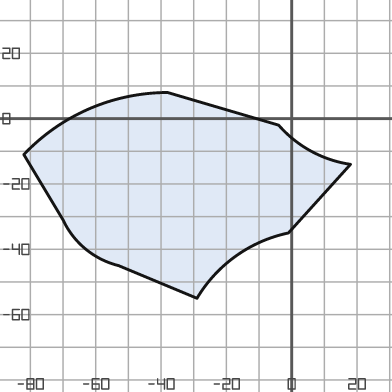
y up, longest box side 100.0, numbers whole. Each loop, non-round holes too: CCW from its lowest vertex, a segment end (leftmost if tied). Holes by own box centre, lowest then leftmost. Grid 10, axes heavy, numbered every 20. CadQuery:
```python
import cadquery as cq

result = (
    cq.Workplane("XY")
    .moveTo(-29.0, -55.0)
    .threePointArc((-17.0, -42.0), (-1.0, -35.0))
    .lineTo(18.0, -14.0)
    .threePointArc((6.0, -10.0), (-4.0, -2.0))
    .lineTo(-38.0, 8.0)
    .threePointArc((-62.0, 3.0), (-82.0, -11.0))
    .lineTo(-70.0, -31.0)
    .threePointArc((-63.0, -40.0), (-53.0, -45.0))
    .close()
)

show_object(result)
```